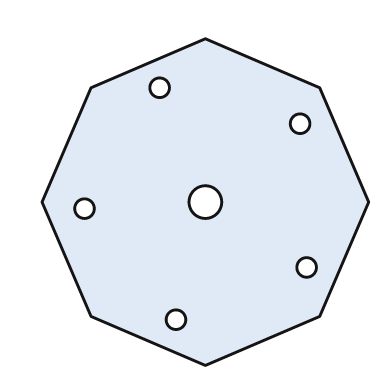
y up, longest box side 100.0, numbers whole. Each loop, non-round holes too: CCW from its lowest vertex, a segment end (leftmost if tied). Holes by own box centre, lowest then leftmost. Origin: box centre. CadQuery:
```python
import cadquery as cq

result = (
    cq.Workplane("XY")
    .moveTo(0.0, -50.0)
    .lineTo(35.0, -35.0)
    .lineTo(50.0, 0.0)
    .lineTo(35.0, 35.0)
    .lineTo(0.0, 50.0)
    .lineTo(-35.0, 35.0)
    .lineTo(-50.0, 0.0)
    .lineTo(-35.0, -35.0)
    .close()
    .moveTo(-9.0, -36.0)
    .circle(3.0)
    .moveTo(31.0, -20.0)
    .circle(3.0)
    .moveTo(-37.0, -2.0)
    .circle(3.0)
    .moveTo(0.0, 0.0)
    .circle(5.0)
    .moveTo(29.0, 24.0)
    .circle(3.0)
    .moveTo(-14.0, 35.0)
    .circle(3.0)
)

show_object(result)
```